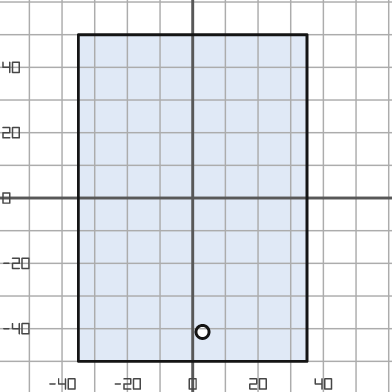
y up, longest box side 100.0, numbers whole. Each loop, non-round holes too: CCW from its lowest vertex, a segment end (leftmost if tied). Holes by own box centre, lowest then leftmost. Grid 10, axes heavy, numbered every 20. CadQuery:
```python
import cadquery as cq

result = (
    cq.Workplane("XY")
    .moveTo(-35.0, -50.0)
    .lineTo(35.0, -50.0)
    .lineTo(35.0, 50.0)
    .lineTo(-35.0, 50.0)
    .close()
    .moveTo(3.0, -41.0)
    .circle(2.0)
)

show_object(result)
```